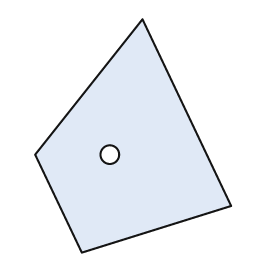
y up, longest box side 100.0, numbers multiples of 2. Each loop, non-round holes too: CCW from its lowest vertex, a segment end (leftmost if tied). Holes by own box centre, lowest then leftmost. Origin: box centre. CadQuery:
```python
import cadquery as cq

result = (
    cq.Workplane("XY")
    .moveTo(-22.0, -50.0)
    .lineTo(42.0, -30.0)
    .lineTo(4.0, 50.0)
    .lineTo(-42.0, -8.0)
    .close()
    .moveTo(-10.0, -8.0)
    .circle(4.0)
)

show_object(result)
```